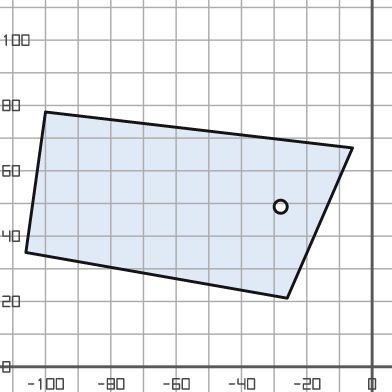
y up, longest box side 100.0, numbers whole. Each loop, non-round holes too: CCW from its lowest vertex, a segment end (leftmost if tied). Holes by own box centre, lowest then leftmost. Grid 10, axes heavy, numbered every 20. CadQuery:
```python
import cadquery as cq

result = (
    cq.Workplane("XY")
    .moveTo(-26.0, 21.0)
    .lineTo(-6.0, 67.0)
    .lineTo(-100.0, 78.0)
    .lineTo(-106.0, 35.0)
    .close()
    .moveTo(-28.0, 49.0)
    .circle(2.0)
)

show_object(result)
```